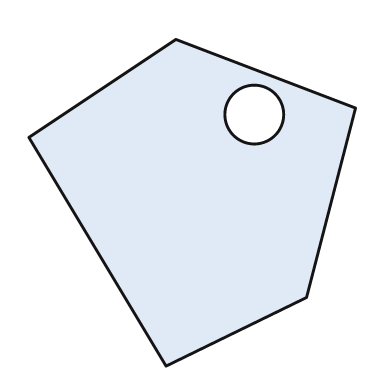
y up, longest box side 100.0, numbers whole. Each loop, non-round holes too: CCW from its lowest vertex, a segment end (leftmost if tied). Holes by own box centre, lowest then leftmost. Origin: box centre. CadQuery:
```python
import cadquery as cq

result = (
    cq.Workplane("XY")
    .moveTo(-8.0, -50.0)
    .lineTo(35.0, -29.0)
    .lineTo(50.0, 29.0)
    .lineTo(-5.0, 50.0)
    .lineTo(-50.0, 20.0)
    .close()
    .moveTo(19.0, 27.0)
    .circle(9.0)
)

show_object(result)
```